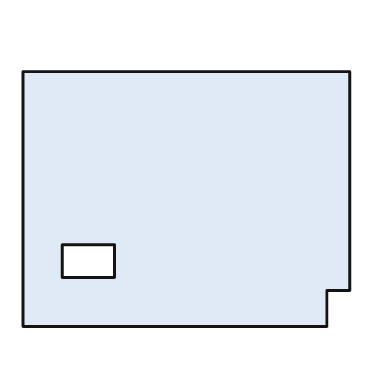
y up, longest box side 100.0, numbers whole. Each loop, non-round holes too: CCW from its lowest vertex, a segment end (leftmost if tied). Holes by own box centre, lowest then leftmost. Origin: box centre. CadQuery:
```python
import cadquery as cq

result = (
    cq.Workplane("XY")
    .moveTo(-50.0, -39.0)
    .lineTo(43.0, -39.0)
    .lineTo(43.0, -28.0)
    .lineTo(50.0, -28.0)
    .lineTo(50.0, 39.0)
    .lineTo(-50.0, 39.0)
    .close()
    .moveTo(-38.0, -24.0)
    .lineTo(-22.0, -24.0)
    .lineTo(-22.0, -14.0)
    .lineTo(-38.0, -14.0)
    .close()
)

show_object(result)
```